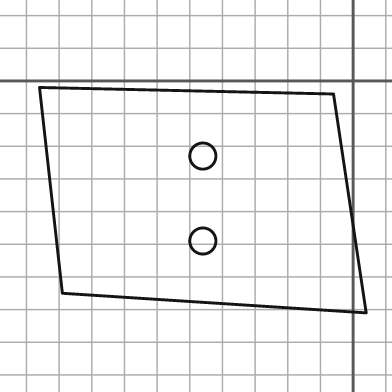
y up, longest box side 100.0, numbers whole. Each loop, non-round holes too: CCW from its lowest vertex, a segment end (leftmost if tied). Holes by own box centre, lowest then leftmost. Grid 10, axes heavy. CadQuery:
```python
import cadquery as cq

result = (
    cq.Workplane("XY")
    .moveTo(4.0, -71.0)
    .lineTo(-6.0, -4.0)
    .lineTo(-96.0, -2.0)
    .lineTo(-89.0, -65.0)
    .close()
    .moveTo(-46.0, -49.0)
    .circle(4.0)
    .moveTo(-46.0, -23.0)
    .circle(4.0)
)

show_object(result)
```